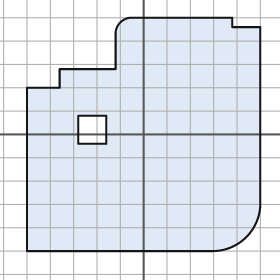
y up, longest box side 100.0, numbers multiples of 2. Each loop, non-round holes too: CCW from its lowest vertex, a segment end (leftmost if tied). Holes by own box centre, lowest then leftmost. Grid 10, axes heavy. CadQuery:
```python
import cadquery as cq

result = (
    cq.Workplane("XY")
    .moveTo(-50.0, -50.0)
    .lineTo(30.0, -50.0)
    .threePointArc((44.0, -44.0), (50.0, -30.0))
    .lineTo(50.0, 46.0)
    .lineTo(38.0, 46.0)
    .lineTo(38.0, 50.0)
    .lineTo(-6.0, 50.0)
    .threePointArc((-10.0, 48.0), (-12.0, 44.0))
    .lineTo(-12.0, 28.0)
    .lineTo(-36.0, 28.0)
    .lineTo(-36.0, 20.0)
    .lineTo(-50.0, 20.0)
    .close()
    .moveTo(-28.0, -4.0)
    .lineTo(-16.0, -4.0)
    .lineTo(-16.0, 8.0)
    .lineTo(-28.0, 8.0)
    .close()
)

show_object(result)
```